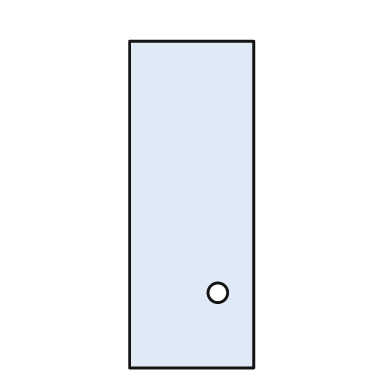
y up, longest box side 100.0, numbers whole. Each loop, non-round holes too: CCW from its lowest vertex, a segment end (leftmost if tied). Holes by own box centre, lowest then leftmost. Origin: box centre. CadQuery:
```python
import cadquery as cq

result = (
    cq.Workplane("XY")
    .moveTo(-19.0, -50.0)
    .lineTo(19.0, -50.0)
    .lineTo(19.0, 50.0)
    .lineTo(-19.0, 50.0)
    .close()
    .moveTo(8.0, -27.0)
    .circle(3.0)
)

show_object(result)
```